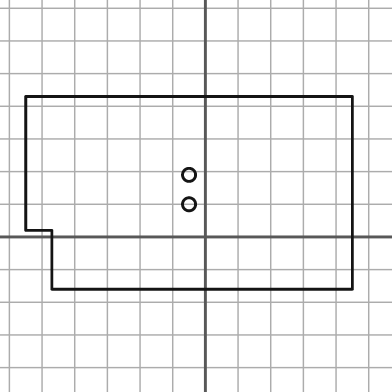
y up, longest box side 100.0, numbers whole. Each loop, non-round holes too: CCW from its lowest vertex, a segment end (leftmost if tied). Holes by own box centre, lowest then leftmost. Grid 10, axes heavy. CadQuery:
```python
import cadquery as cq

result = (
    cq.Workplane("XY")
    .moveTo(-47.0, -16.0)
    .lineTo(45.0, -16.0)
    .lineTo(45.0, 43.0)
    .lineTo(-55.0, 43.0)
    .lineTo(-55.0, 2.0)
    .lineTo(-47.0, 2.0)
    .close()
    .moveTo(-5.0, 10.0)
    .circle(2.0)
    .moveTo(-5.0, 19.0)
    .circle(2.0)
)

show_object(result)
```